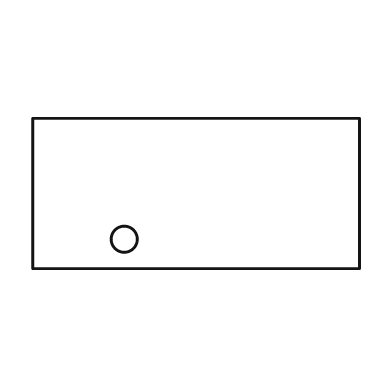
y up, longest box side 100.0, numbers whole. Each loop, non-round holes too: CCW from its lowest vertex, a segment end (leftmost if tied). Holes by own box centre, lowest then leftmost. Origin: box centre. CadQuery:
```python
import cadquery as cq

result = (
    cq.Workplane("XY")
    .moveTo(-50.0, -23.0)
    .lineTo(50.0, -23.0)
    .lineTo(50.0, 23.0)
    .lineTo(-50.0, 23.0)
    .close()
    .moveTo(-22.0, -14.0)
    .circle(4.0)
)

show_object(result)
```